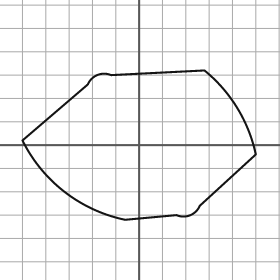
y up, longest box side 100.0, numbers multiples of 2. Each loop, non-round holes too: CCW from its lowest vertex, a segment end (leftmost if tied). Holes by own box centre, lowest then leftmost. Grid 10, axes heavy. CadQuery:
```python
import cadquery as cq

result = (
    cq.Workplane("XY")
    .moveTo(-6.0, -32.0)
    .lineTo(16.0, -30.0)
    .threePointArc((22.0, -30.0), (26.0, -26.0))
    .lineTo(50.0, -4.0)
    .threePointArc((42.0, 16.0), (28.0, 32.0))
    .lineTo(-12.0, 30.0)
    .threePointArc((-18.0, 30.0), (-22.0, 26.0))
    .lineTo(-50.0, 2.0)
    .threePointArc((-32.0, -20.0), (-6.0, -32.0))
    .close()
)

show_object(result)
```